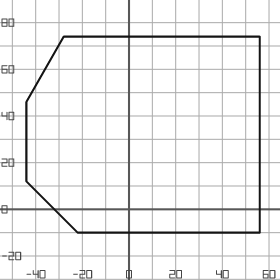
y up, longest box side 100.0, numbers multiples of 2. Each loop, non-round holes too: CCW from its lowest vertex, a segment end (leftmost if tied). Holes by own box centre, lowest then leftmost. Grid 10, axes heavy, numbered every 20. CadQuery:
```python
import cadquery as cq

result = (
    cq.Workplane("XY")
    .moveTo(-22.0, -10.0)
    .lineTo(56.0, -10.0)
    .lineTo(56.0, 74.0)
    .lineTo(-28.0, 74.0)
    .lineTo(-44.0, 46.0)
    .lineTo(-44.0, 12.0)
    .close()
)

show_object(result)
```